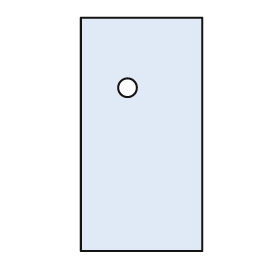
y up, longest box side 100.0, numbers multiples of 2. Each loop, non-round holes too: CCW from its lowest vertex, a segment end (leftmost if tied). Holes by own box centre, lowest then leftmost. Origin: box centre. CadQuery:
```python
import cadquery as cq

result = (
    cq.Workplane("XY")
    .moveTo(-26.0, -50.0)
    .lineTo(26.0, -50.0)
    .lineTo(26.0, 50.0)
    .lineTo(-26.0, 50.0)
    .close()
    .moveTo(-6.0, 20.0)
    .circle(4.0)
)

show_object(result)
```